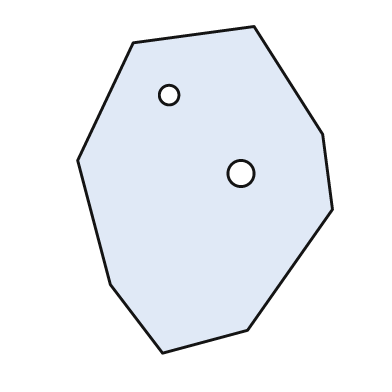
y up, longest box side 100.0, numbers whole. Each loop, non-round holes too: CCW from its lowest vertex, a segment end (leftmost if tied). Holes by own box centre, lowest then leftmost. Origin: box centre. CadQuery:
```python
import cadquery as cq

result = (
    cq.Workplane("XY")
    .moveTo(-13.0, -50.0)
    .lineTo(13.0, -43.0)
    .lineTo(39.0, -6.0)
    .lineTo(36.0, 17.0)
    .lineTo(15.0, 50.0)
    .lineTo(-22.0, 45.0)
    .lineTo(-39.0, 9.0)
    .lineTo(-29.0, -29.0)
    .close()
    .moveTo(11.0, 5.0)
    .circle(4.0)
    .moveTo(-11.0, 29.0)
    .circle(3.0)
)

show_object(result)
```